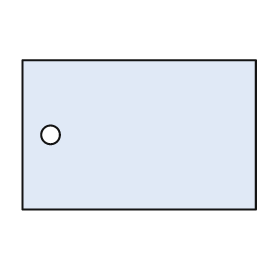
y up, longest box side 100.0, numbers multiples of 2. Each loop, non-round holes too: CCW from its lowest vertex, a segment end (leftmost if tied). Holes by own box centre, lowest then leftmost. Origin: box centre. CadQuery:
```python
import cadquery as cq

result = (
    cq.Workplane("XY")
    .moveTo(-50.0, -32.0)
    .lineTo(50.0, -32.0)
    .lineTo(50.0, 32.0)
    .lineTo(-50.0, 32.0)
    .close()
    .moveTo(-38.0, 0.0)
    .circle(4.0)
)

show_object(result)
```